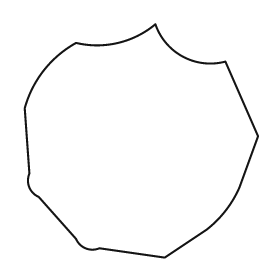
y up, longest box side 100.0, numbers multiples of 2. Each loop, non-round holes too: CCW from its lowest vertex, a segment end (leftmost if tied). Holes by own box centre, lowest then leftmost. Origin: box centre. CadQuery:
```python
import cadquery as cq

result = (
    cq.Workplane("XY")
    .moveTo(10.0, -50.0)
    .lineTo(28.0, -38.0)
    .threePointArc((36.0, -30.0), (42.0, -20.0))
    .lineTo(50.0, 2.0)
    .lineTo(36.0, 34.0)
    .threePointArc((18.0, 36.0), (6.0, 50.0))
    .threePointArc((-10.0, 42.0), (-28.0, 42.0))
    .threePointArc((-42.0, 30.0), (-50.0, 14.0))
    .lineTo(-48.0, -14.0)
    .threePointArc((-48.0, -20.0), (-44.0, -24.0))
    .lineTo(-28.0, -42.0)
    .threePointArc((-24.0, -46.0), (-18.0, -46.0))
    .close()
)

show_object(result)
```